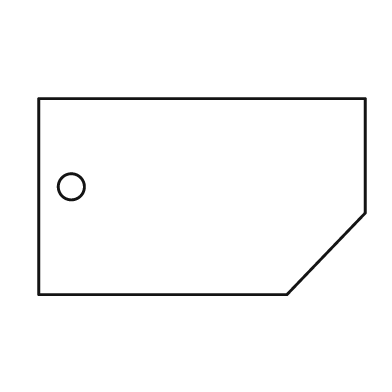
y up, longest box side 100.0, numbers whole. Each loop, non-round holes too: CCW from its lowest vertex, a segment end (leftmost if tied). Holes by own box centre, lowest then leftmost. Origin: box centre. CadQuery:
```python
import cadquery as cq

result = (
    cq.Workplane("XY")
    .moveTo(-50.0, -30.0)
    .lineTo(26.0, -30.0)
    .lineTo(50.0, -5.0)
    .lineTo(50.0, 30.0)
    .lineTo(-50.0, 30.0)
    .close()
    .moveTo(-40.0, 3.0)
    .circle(4.0)
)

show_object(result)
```